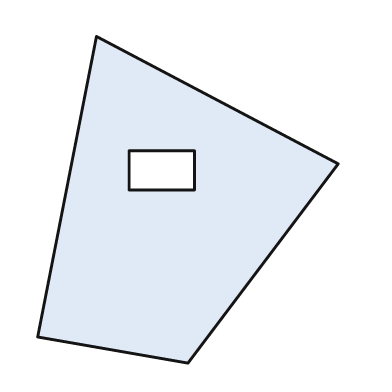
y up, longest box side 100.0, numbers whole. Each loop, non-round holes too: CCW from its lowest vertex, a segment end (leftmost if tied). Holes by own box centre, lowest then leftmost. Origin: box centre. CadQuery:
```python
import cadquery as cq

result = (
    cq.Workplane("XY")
    .moveTo(0.0, -50.0)
    .lineTo(46.0, 11.0)
    .lineTo(-28.0, 50.0)
    .lineTo(-46.0, -42.0)
    .close()
    .moveTo(-18.0, 3.0)
    .lineTo(2.0, 3.0)
    .lineTo(2.0, 15.0)
    .lineTo(-18.0, 15.0)
    .close()
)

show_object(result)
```